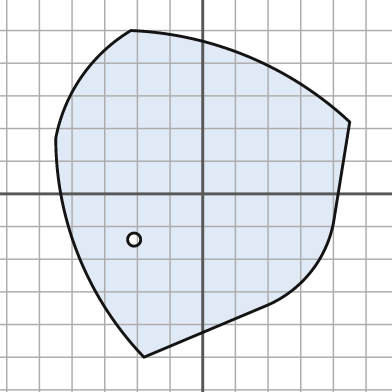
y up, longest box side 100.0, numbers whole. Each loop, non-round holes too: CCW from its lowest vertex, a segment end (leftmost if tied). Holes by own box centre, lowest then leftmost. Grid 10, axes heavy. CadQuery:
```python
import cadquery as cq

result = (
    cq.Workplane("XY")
    .moveTo(-18.0, -50.0)
    .lineTo(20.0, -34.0)
    .threePointArc((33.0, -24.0), (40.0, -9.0))
    .lineTo(45.0, 22.0)
    .threePointArc((14.0, 42.0), (-22.0, 50.0))
    .threePointArc((-37.0, 36.0), (-45.0, 17.0))
    .threePointArc((-38.0, -19.0), (-18.0, -50.0))
    .close()
    .moveTo(-21.0, -14.0)
    .circle(2.0)
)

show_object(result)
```